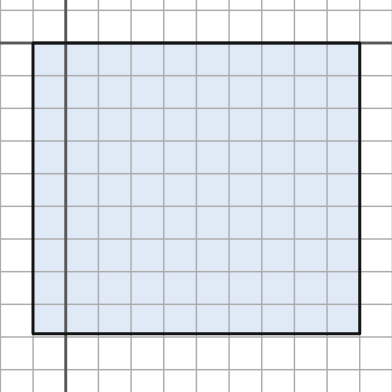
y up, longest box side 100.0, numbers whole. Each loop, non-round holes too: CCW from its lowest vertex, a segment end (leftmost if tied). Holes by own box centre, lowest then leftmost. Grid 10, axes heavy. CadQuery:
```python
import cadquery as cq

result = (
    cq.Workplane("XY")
    .moveTo(-10.0, -89.0)
    .lineTo(90.0, -89.0)
    .lineTo(90.0, 0.0)
    .lineTo(-10.0, 0.0)
    .close()
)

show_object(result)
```